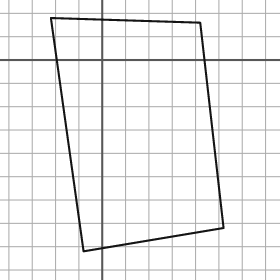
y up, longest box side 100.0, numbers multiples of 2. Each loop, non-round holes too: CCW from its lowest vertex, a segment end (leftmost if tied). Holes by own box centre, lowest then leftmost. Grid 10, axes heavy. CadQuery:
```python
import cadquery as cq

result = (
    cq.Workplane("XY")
    .moveTo(-8.0, -82.0)
    .lineTo(52.0, -72.0)
    .lineTo(42.0, 16.0)
    .lineTo(-22.0, 18.0)
    .close()
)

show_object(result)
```